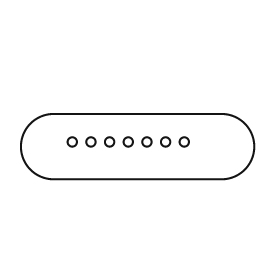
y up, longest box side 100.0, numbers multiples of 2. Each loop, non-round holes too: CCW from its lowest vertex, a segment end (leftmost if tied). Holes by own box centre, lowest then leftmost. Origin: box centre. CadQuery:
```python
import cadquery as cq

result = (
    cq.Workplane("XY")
    .moveTo(-36.0, -14.0)
    .lineTo(36.0, -14.0)
    .threePointArc((50.0, 0.0), (36.0, 14.0))
    .lineTo(-36.0, 14.0)
    .threePointArc((-50.0, 0.0), (-36.0, -14.0))
    .close()
    .moveTo(-28.0, 2.0)
    .circle(2.0)
    .moveTo(-20.0, 2.0)
    .circle(2.0)
    .moveTo(-12.0, 2.0)
    .circle(2.0)
    .moveTo(-4.0, 2.0)
    .circle(2.0)
    .moveTo(4.0, 2.0)
    .circle(2.0)
    .moveTo(12.0, 2.0)
    .circle(2.0)
    .moveTo(20.0, 2.0)
    .circle(2.0)
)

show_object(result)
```